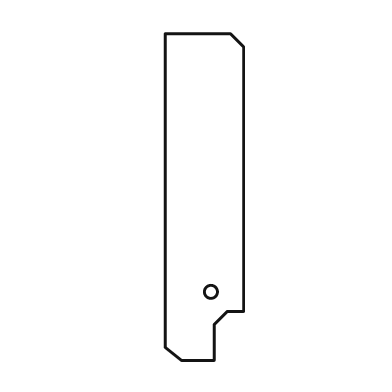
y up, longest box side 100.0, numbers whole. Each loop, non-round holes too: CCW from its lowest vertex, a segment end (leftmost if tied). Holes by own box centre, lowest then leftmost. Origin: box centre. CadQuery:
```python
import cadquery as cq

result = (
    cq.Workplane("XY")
    .moveTo(-7.0, -50.0)
    .lineTo(3.0, -50.0)
    .lineTo(3.0, -39.0)
    .lineTo(7.0, -35.0)
    .lineTo(12.0, -35.0)
    .lineTo(12.0, 46.0)
    .lineTo(8.0, 50.0)
    .lineTo(-12.0, 50.0)
    .lineTo(-12.0, -46.0)
    .close()
    .moveTo(2.0, -29.0)
    .circle(2.0)
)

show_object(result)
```